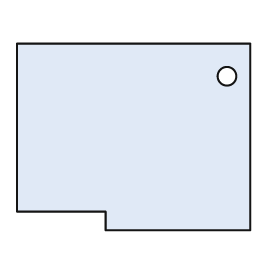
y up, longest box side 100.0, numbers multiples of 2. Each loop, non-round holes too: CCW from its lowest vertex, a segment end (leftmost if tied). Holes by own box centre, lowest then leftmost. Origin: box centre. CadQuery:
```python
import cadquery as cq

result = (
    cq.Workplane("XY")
    .moveTo(-12.0, -40.0)
    .lineTo(50.0, -40.0)
    .lineTo(50.0, 40.0)
    .lineTo(-50.0, 40.0)
    .lineTo(-50.0, -32.0)
    .lineTo(-12.0, -32.0)
    .close()
    .moveTo(40.0, 26.0)
    .circle(4.0)
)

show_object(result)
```